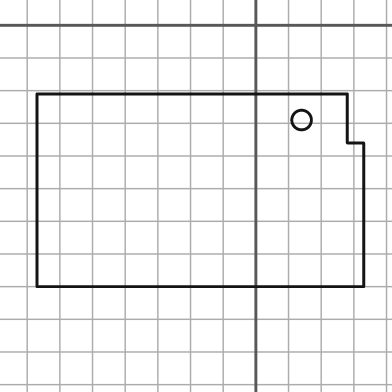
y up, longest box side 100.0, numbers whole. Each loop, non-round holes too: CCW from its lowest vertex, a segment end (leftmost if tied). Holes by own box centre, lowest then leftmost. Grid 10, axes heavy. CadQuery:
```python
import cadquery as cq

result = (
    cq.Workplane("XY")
    .moveTo(-67.0, -80.0)
    .lineTo(33.0, -80.0)
    .lineTo(33.0, -36.0)
    .lineTo(28.0, -36.0)
    .lineTo(28.0, -21.0)
    .lineTo(-67.0, -21.0)
    .close()
    .moveTo(14.0, -29.0)
    .circle(3.0)
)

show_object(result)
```